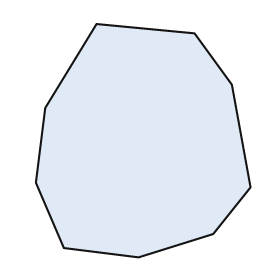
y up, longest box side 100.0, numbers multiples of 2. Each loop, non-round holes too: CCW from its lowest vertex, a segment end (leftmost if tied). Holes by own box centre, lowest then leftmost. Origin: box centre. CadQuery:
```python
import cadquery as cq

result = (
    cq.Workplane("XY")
    .moveTo(-2.0, -50.0)
    .lineTo(30.0, -40.0)
    .lineTo(46.0, -20.0)
    .lineTo(38.0, 24.0)
    .lineTo(22.0, 46.0)
    .lineTo(-20.0, 50.0)
    .lineTo(-42.0, 14.0)
    .lineTo(-46.0, -18.0)
    .lineTo(-34.0, -46.0)
    .close()
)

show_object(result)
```